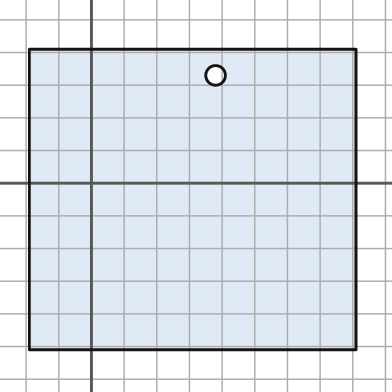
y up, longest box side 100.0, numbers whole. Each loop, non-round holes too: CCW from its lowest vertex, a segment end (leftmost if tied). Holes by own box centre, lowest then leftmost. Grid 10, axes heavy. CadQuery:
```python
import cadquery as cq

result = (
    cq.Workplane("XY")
    .moveTo(-19.0, -51.0)
    .lineTo(81.0, -51.0)
    .lineTo(81.0, 41.0)
    .lineTo(-19.0, 41.0)
    .close()
    .moveTo(38.0, 33.0)
    .circle(3.0)
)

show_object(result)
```